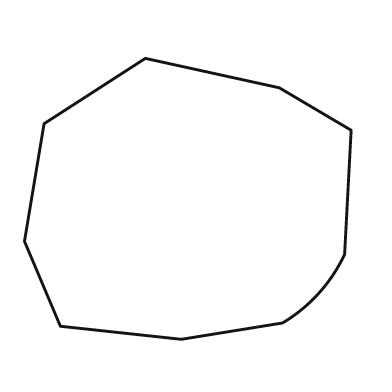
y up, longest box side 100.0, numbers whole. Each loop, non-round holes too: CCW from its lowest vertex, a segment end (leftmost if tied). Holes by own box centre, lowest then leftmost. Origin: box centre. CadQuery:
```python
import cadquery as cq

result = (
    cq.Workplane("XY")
    .moveTo(-2.0, -43.0)
    .lineTo(29.0, -38.0)
    .threePointArc((40.0, -29.0), (48.0, -17.0))
    .lineTo(50.0, 21.0)
    .lineTo(28.0, 34.0)
    .lineTo(-13.0, 43.0)
    .lineTo(-44.0, 23.0)
    .lineTo(-50.0, -13.0)
    .lineTo(-39.0, -39.0)
    .close()
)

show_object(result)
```